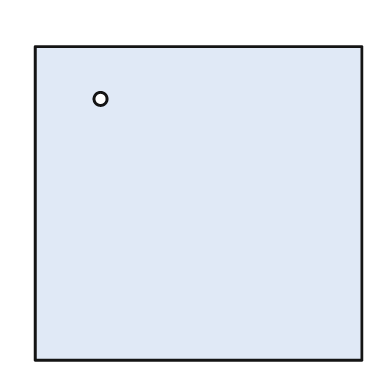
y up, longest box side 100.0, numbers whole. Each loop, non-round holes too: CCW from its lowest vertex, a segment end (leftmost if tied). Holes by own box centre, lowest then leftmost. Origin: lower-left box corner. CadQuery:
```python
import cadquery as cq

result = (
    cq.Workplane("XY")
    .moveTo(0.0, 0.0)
    .lineTo(100.0, 0.0)
    .lineTo(100.0, 96.0)
    .lineTo(0.0, 96.0)
    .close()
    .moveTo(20.0, 80.0)
    .circle(2.0)
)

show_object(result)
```